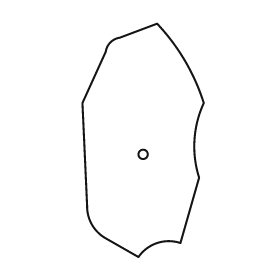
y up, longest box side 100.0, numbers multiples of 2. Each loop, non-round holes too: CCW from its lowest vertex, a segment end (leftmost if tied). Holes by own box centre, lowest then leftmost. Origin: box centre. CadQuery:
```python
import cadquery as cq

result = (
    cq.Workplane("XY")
    .moveTo(-2.0, -50.0)
    .threePointArc((6.0, -44.0), (16.0, -44.0))
    .lineTo(24.0, -16.0)
    .threePointArc((22.0, 0.0), (26.0, 16.0))
    .threePointArc((18.0, 34.0), (6.0, 50.0))
    .lineTo(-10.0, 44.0)
    .threePointArc((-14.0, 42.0), (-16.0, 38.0))
    .lineTo(-26.0, 16.0)
    .lineTo(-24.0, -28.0)
    .threePointArc((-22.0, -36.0), (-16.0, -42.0))
    .close()
    .moveTo(0.0, -6.0)
    .circle(2.0)
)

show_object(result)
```